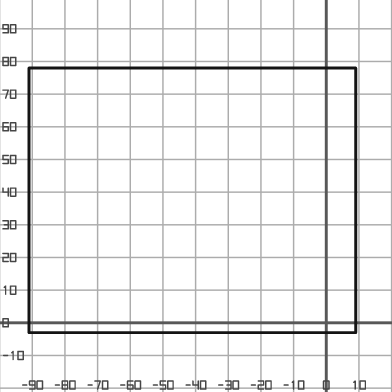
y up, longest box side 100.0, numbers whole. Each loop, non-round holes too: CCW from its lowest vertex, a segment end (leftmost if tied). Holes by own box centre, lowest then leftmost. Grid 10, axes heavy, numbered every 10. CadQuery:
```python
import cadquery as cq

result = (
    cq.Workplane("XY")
    .moveTo(-91.0, -3.0)
    .lineTo(9.0, -3.0)
    .lineTo(9.0, 78.0)
    .lineTo(-91.0, 78.0)
    .close()
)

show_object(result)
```